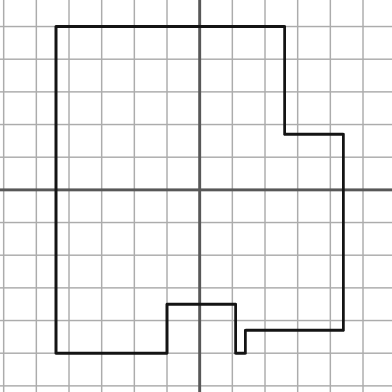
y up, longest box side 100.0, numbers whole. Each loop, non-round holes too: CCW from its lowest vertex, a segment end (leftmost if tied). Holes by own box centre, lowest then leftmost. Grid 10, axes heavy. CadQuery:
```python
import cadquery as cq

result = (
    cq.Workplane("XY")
    .moveTo(-44.0, -50.0)
    .lineTo(-10.0, -50.0)
    .lineTo(-10.0, -35.0)
    .lineTo(11.0, -35.0)
    .lineTo(11.0, -50.0)
    .lineTo(14.0, -50.0)
    .lineTo(14.0, -43.0)
    .lineTo(44.0, -43.0)
    .lineTo(44.0, 17.0)
    .lineTo(26.0, 17.0)
    .lineTo(26.0, 50.0)
    .lineTo(-44.0, 50.0)
    .close()
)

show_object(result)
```